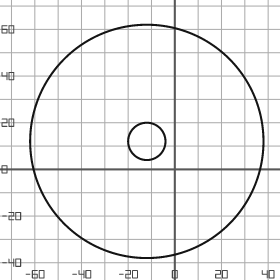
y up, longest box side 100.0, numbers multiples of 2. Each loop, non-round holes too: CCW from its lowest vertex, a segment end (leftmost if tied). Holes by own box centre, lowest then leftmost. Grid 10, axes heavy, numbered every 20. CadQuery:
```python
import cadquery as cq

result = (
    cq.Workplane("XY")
    .moveTo(-12.0, 12.0)
    .circle(50.0)
    .moveTo(-12.0, 12.0)
    .circle(8.0)
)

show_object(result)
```